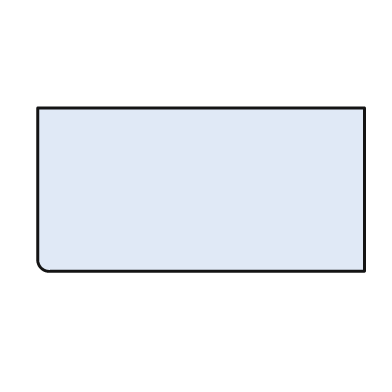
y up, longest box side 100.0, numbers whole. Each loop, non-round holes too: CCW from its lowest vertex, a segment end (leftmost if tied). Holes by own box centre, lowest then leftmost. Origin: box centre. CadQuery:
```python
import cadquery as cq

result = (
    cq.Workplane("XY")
    .moveTo(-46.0, -25.0)
    .lineTo(50.0, -25.0)
    .lineTo(50.0, 25.0)
    .lineTo(-50.0, 25.0)
    .lineTo(-50.0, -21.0)
    .threePointArc((-49.0, -24.0), (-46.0, -25.0))
    .close()
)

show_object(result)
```